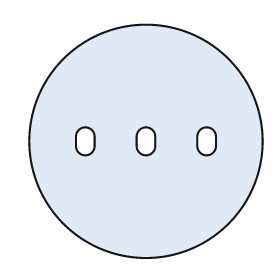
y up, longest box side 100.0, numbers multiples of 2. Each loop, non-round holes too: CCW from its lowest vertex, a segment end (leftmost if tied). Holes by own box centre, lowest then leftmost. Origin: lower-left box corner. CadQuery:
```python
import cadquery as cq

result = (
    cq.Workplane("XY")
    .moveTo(50.0, 50.0)
    .circle(50.0)
    .moveTo(20.0, 48.0)
    .threePointArc((24.0, 44.0), (28.0, 48.0))
    .lineTo(28.0, 52.0)
    .threePointArc((24.0, 56.0), (20.0, 52.0))
    .close()
    .moveTo(46.0, 48.0)
    .threePointArc((50.0, 44.0), (54.0, 48.0))
    .lineTo(54.0, 52.0)
    .threePointArc((50.0, 56.0), (46.0, 52.0))
    .close()
    .moveTo(72.0, 48.0)
    .threePointArc((76.0, 44.0), (80.0, 48.0))
    .lineTo(80.0, 52.0)
    .threePointArc((76.0, 56.0), (72.0, 52.0))
    .close()
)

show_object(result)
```